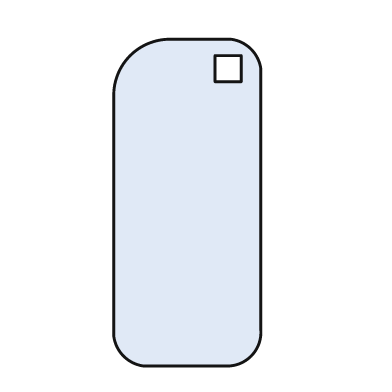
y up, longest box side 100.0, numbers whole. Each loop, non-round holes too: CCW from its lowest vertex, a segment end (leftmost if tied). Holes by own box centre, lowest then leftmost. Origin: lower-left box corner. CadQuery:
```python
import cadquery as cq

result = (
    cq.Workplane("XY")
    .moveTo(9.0, 0.0)
    .lineTo(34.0, 0.0)
    .threePointArc((42.0, 3.0), (45.0, 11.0))
    .lineTo(45.0, 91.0)
    .threePointArc((42.0, 97.0), (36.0, 100.0))
    .lineTo(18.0, 100.0)
    .threePointArc((5.0, 95.0), (0.0, 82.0))
    .lineTo(0.0, 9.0)
    .threePointArc((3.0, 3.0), (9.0, 0.0))
    .close()
    .moveTo(31.0, 87.0)
    .lineTo(39.0, 87.0)
    .lineTo(39.0, 95.0)
    .lineTo(31.0, 95.0)
    .close()
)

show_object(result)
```